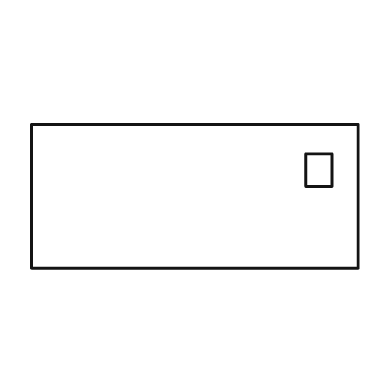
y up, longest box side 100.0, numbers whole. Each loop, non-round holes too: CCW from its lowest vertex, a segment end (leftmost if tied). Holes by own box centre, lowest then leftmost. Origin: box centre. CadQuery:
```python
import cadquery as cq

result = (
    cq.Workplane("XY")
    .moveTo(-50.0, -22.0)
    .lineTo(50.0, -22.0)
    .lineTo(50.0, 22.0)
    .lineTo(-50.0, 22.0)
    .close()
    .moveTo(34.0, 3.0)
    .lineTo(42.0, 3.0)
    .lineTo(42.0, 13.0)
    .lineTo(34.0, 13.0)
    .close()
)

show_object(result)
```